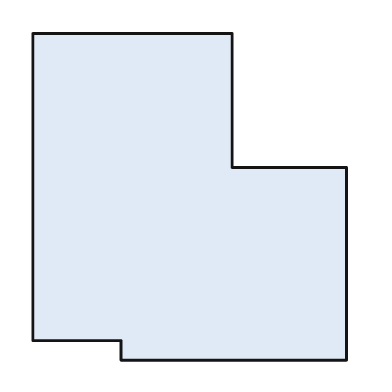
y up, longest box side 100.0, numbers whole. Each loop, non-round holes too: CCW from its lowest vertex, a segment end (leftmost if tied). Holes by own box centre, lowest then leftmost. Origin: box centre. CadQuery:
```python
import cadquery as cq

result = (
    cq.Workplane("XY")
    .moveTo(-21.0, -50.0)
    .lineTo(48.0, -50.0)
    .lineTo(48.0, 9.0)
    .lineTo(13.0, 9.0)
    .lineTo(13.0, 50.0)
    .lineTo(-48.0, 50.0)
    .lineTo(-48.0, -44.0)
    .lineTo(-21.0, -44.0)
    .close()
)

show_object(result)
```